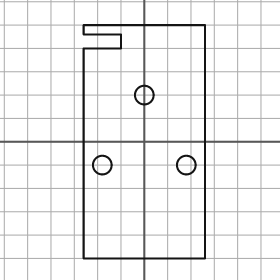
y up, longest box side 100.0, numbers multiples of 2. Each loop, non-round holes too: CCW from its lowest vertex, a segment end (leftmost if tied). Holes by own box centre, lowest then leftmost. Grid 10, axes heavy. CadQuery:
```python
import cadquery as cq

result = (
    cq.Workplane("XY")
    .moveTo(-26.0, -50.0)
    .lineTo(26.0, -50.0)
    .lineTo(26.0, 50.0)
    .lineTo(-26.0, 50.0)
    .lineTo(-26.0, 46.0)
    .lineTo(-10.0, 46.0)
    .lineTo(-10.0, 40.0)
    .lineTo(-26.0, 40.0)
    .close()
    .moveTo(-18.0, -10.0)
    .circle(4.0)
    .moveTo(18.0, -10.0)
    .circle(4.0)
    .moveTo(0.0, 20.0)
    .circle(4.0)
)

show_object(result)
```